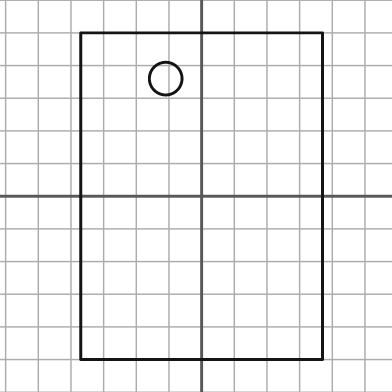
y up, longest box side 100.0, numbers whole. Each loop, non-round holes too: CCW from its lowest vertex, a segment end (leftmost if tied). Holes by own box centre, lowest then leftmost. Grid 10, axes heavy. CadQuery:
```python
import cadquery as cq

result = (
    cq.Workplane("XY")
    .moveTo(-37.0, -50.0)
    .lineTo(37.0, -50.0)
    .lineTo(37.0, 50.0)
    .lineTo(-37.0, 50.0)
    .close()
    .moveTo(-11.0, 36.0)
    .circle(5.0)
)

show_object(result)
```